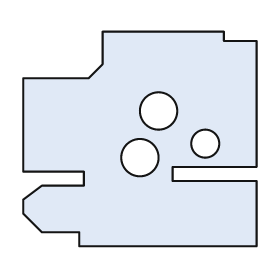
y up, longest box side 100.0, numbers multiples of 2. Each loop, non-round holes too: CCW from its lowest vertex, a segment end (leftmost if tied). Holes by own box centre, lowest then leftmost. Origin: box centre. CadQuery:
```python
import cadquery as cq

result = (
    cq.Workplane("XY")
    .moveTo(-26.0, -46.0)
    .lineTo(50.0, -46.0)
    .lineTo(50.0, -18.0)
    .lineTo(14.0, -18.0)
    .lineTo(14.0, -12.0)
    .lineTo(50.0, -12.0)
    .lineTo(50.0, 42.0)
    .lineTo(36.0, 42.0)
    .lineTo(36.0, 46.0)
    .lineTo(-16.0, 46.0)
    .lineTo(-16.0, 32.0)
    .lineTo(-22.0, 26.0)
    .lineTo(-50.0, 26.0)
    .lineTo(-50.0, -14.0)
    .lineTo(-24.0, -14.0)
    .lineTo(-24.0, -20.0)
    .lineTo(-42.0, -20.0)
    .lineTo(-50.0, -26.0)
    .lineTo(-50.0, -32.0)
    .lineTo(-42.0, -40.0)
    .lineTo(-26.0, -40.0)
    .close()
    .moveTo(0.0, -8.0)
    .circle(8.0)
    .moveTo(28.0, -2.0)
    .circle(6.0)
    .moveTo(8.0, 12.0)
    .circle(8.0)
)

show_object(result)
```